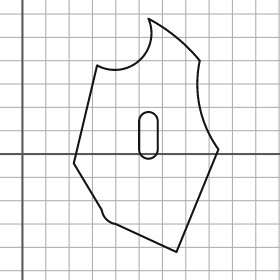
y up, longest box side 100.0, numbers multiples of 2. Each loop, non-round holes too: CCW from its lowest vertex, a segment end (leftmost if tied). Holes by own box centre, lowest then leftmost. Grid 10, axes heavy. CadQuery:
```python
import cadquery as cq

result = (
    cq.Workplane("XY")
    .moveTo(66.0, -42.0)
    .lineTo(84.0, 2.0)
    .threePointArc((76.0, 20.0), (76.0, 40.0))
    .threePointArc((66.0, 50.0), (54.0, 58.0))
    .threePointArc((50.0, 40.0), (32.0, 38.0))
    .lineTo(22.0, -4.0)
    .lineTo(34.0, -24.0)
    .threePointArc((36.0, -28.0), (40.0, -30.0))
    .close()
    .moveTo(50.0, 2.0)
    .threePointArc((54.0, -2.0), (58.0, 2.0))
    .lineTo(58.0, 14.0)
    .threePointArc((54.0, 18.0), (50.0, 14.0))
    .close()
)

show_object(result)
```